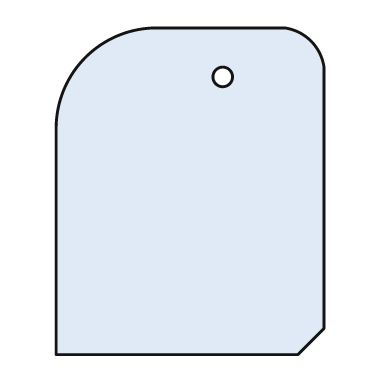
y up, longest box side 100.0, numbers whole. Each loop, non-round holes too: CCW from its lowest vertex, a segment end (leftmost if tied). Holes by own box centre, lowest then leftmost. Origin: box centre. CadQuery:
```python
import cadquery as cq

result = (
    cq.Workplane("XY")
    .moveTo(-41.0, -50.0)
    .lineTo(33.0, -50.0)
    .lineTo(41.0, -42.0)
    .lineTo(41.0, 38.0)
    .threePointArc((37.0, 46.0), (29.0, 50.0))
    .lineTo(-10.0, 50.0)
    .threePointArc((-32.0, 41.0), (-41.0, 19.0))
    .close()
    .moveTo(10.0, 35.0)
    .circle(3.0)
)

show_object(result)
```